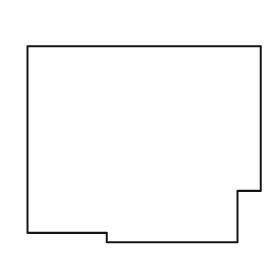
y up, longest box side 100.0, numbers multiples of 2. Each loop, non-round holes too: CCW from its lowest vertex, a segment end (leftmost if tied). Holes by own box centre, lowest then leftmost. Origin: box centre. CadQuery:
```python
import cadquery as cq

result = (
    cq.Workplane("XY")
    .moveTo(-16.0, -42.0)
    .lineTo(40.0, -42.0)
    .lineTo(40.0, -20.0)
    .lineTo(50.0, -20.0)
    .lineTo(50.0, 42.0)
    .lineTo(-50.0, 42.0)
    .lineTo(-50.0, -38.0)
    .lineTo(-16.0, -38.0)
    .close()
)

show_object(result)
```